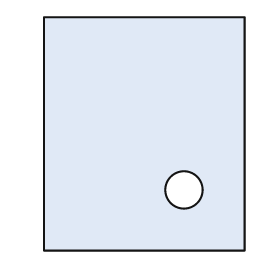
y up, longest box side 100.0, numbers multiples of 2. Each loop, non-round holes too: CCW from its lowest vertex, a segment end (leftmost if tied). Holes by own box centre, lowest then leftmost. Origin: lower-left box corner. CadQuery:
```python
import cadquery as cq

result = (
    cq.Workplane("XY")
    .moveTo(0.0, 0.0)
    .lineTo(86.0, 0.0)
    .lineTo(86.0, 100.0)
    .lineTo(0.0, 100.0)
    .close()
    .moveTo(60.0, 26.0)
    .circle(8.0)
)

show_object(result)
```